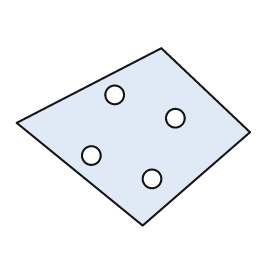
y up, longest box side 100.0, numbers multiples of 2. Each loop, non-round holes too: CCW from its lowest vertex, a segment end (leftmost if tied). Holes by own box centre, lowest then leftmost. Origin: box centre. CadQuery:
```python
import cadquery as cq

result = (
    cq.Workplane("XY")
    .moveTo(4.0, -38.0)
    .lineTo(50.0, 2.0)
    .lineTo(12.0, 38.0)
    .lineTo(-50.0, 6.0)
    .close()
    .moveTo(8.0, -18.0)
    .circle(4.0)
    .moveTo(-18.0, -8.0)
    .circle(4.0)
    .moveTo(18.0, 8.0)
    .circle(4.0)
    .moveTo(-8.0, 18.0)
    .circle(4.0)
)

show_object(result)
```